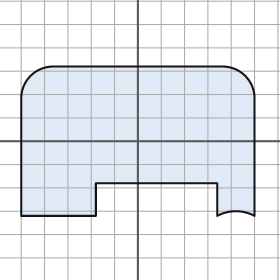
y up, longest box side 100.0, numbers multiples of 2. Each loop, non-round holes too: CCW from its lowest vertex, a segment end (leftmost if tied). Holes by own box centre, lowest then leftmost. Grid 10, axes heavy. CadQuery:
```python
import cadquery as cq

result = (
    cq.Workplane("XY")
    .moveTo(-50.0, -32.0)
    .lineTo(-18.0, -32.0)
    .lineTo(-18.0, -18.0)
    .lineTo(34.0, -18.0)
    .lineTo(34.0, -32.0)
    .threePointArc((42.0, -30.0), (50.0, -32.0))
    .lineTo(50.0, 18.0)
    .threePointArc((46.0, 28.0), (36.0, 32.0))
    .lineTo(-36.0, 32.0)
    .threePointArc((-46.0, 28.0), (-50.0, 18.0))
    .close()
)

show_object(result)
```